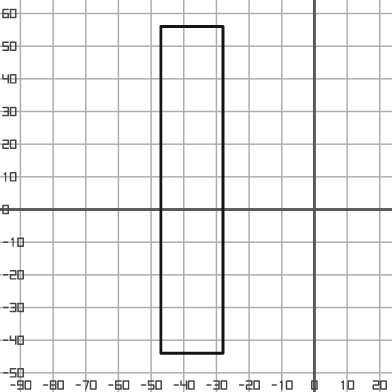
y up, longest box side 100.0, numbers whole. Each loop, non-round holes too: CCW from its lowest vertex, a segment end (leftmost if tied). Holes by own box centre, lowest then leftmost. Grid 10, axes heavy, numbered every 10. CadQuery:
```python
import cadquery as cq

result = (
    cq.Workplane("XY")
    .moveTo(-47.0, -44.0)
    .lineTo(-28.0, -44.0)
    .lineTo(-28.0, 56.0)
    .lineTo(-47.0, 56.0)
    .close()
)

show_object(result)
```